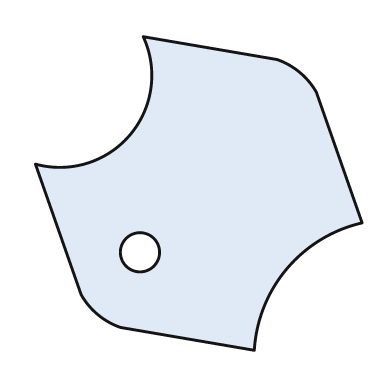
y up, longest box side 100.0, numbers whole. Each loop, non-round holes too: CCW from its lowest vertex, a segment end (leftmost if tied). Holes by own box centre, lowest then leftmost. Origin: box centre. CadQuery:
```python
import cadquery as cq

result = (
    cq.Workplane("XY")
    .moveTo(17.0, -48.0)
    .threePointArc((27.0, -23.0), (50.0, -9.0))
    .lineTo(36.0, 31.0)
    .threePointArc((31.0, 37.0), (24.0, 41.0))
    .lineTo(-17.0, 48.0)
    .threePointArc((-21.0, 18.0), (-50.0, 9.0))
    .lineTo(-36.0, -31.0)
    .threePointArc((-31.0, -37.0), (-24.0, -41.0))
    .close()
    .moveTo(-18.0, -18.0)
    .circle(6.0)
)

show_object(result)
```